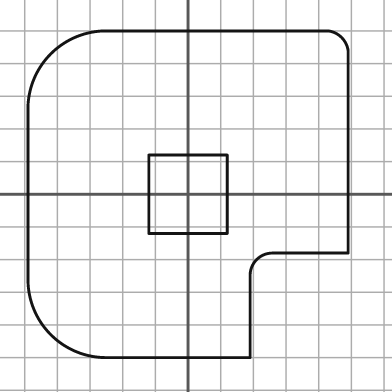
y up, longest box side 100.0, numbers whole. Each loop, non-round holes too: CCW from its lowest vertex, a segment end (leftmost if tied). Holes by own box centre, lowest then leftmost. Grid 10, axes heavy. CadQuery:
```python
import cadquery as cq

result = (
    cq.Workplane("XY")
    .moveTo(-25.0, -50.0)
    .lineTo(19.0, -50.0)
    .lineTo(19.0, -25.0)
    .threePointArc((21.0, -20.0), (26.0, -18.0))
    .lineTo(49.0, -18.0)
    .lineTo(49.0, 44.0)
    .threePointArc((47.0, 48.0), (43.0, 50.0))
    .lineTo(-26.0, 50.0)
    .threePointArc((-42.0, 43.0), (-49.0, 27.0))
    .lineTo(-49.0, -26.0)
    .threePointArc((-42.0, -43.0), (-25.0, -50.0))
    .close()
    .moveTo(-12.0, -12.0)
    .lineTo(12.0, -12.0)
    .lineTo(12.0, 12.0)
    .lineTo(-12.0, 12.0)
    .close()
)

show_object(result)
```